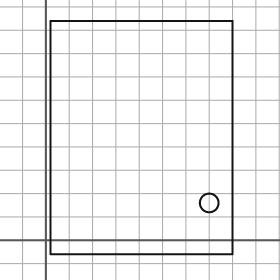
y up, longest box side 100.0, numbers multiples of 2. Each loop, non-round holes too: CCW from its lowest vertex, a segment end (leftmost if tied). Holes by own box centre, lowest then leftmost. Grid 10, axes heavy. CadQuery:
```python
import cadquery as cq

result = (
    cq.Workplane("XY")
    .moveTo(2.0, -6.0)
    .lineTo(80.0, -6.0)
    .lineTo(80.0, 94.0)
    .lineTo(2.0, 94.0)
    .close()
    .moveTo(70.0, 16.0)
    .circle(4.0)
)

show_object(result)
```